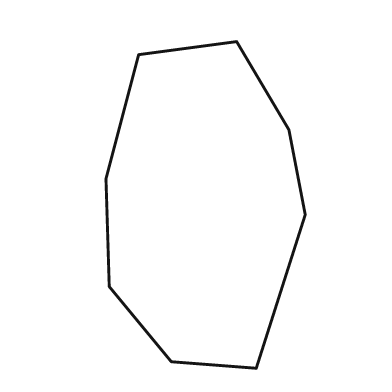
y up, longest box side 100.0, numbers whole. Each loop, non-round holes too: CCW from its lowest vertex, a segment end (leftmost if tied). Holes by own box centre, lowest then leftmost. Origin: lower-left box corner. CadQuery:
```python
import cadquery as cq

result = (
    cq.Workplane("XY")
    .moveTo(46.0, 0.0)
    .lineTo(61.0, 47.0)
    .lineTo(56.0, 73.0)
    .lineTo(40.0, 100.0)
    .lineTo(10.0, 96.0)
    .lineTo(0.0, 58.0)
    .lineTo(1.0, 25.0)
    .lineTo(20.0, 2.0)
    .close()
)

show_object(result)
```